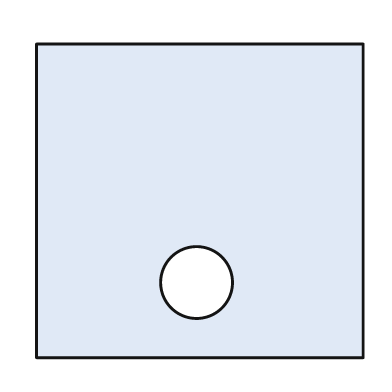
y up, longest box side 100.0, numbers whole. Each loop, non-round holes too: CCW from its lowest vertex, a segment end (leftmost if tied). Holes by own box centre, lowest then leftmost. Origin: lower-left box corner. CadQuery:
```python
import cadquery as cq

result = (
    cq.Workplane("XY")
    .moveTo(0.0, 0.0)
    .lineTo(100.0, 0.0)
    .lineTo(100.0, 96.0)
    .lineTo(0.0, 96.0)
    .close()
    .moveTo(49.0, 23.0)
    .circle(11.0)
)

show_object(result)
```